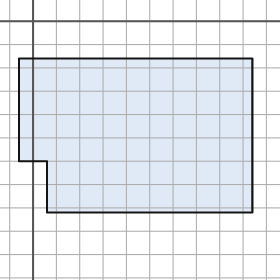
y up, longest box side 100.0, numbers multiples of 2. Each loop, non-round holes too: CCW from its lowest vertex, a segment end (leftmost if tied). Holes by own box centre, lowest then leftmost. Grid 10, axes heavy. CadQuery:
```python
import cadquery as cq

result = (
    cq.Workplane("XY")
    .moveTo(6.0, -82.0)
    .lineTo(94.0, -82.0)
    .lineTo(94.0, -16.0)
    .lineTo(-6.0, -16.0)
    .lineTo(-6.0, -60.0)
    .lineTo(6.0, -60.0)
    .close()
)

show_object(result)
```